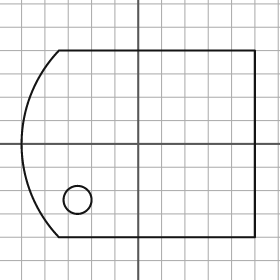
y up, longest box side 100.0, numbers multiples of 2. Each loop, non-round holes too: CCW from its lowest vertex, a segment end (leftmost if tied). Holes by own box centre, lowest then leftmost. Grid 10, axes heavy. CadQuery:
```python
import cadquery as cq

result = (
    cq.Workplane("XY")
    .moveTo(-34.0, -40.0)
    .lineTo(50.0, -40.0)
    .lineTo(50.0, 40.0)
    .lineTo(-34.0, 40.0)
    .threePointArc((-50.0, 0.0), (-34.0, -40.0))
    .close()
    .moveTo(-26.0, -24.0)
    .circle(6.0)
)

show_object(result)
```